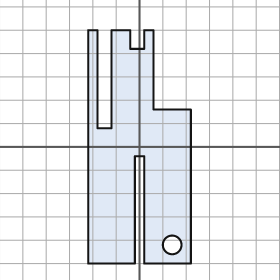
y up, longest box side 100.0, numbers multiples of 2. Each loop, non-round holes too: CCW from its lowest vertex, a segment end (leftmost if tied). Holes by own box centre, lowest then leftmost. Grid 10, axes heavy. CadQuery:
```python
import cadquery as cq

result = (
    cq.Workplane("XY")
    .moveTo(-22.0, -50.0)
    .lineTo(-2.0, -50.0)
    .lineTo(-2.0, -4.0)
    .lineTo(2.0, -4.0)
    .lineTo(2.0, -50.0)
    .lineTo(22.0, -50.0)
    .lineTo(22.0, 16.0)
    .lineTo(6.0, 16.0)
    .lineTo(6.0, 50.0)
    .lineTo(2.0, 50.0)
    .lineTo(2.0, 42.0)
    .lineTo(-4.0, 42.0)
    .lineTo(-4.0, 50.0)
    .lineTo(-12.0, 50.0)
    .lineTo(-12.0, 8.0)
    .lineTo(-18.0, 8.0)
    .lineTo(-18.0, 50.0)
    .lineTo(-22.0, 50.0)
    .close()
    .moveTo(14.0, -42.0)
    .circle(4.0)
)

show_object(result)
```